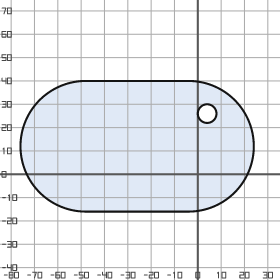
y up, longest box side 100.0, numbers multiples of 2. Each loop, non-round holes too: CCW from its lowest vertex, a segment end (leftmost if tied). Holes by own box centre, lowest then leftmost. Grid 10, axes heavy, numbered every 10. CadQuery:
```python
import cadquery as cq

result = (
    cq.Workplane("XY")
    .moveTo(-48.0, -16.0)
    .lineTo(-4.0, -16.0)
    .threePointArc((24.0, 12.0), (-4.0, 40.0))
    .lineTo(-48.0, 40.0)
    .threePointArc((-76.0, 12.0), (-48.0, -16.0))
    .close()
    .moveTo(4.0, 26.0)
    .circle(4.0)
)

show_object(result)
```